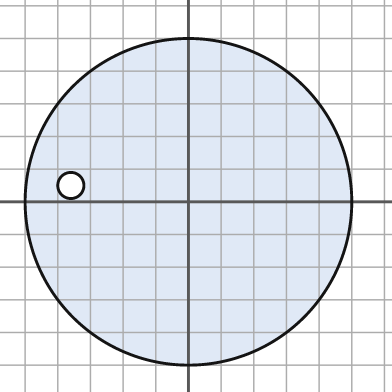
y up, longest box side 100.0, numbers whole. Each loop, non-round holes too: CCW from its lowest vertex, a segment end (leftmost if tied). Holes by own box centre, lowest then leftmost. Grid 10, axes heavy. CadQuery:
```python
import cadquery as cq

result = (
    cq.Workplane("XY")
    .moveTo(0.0, 0.0)
    .circle(50.0)
    .moveTo(-36.0, 5.0)
    .circle(4.0)
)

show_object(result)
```